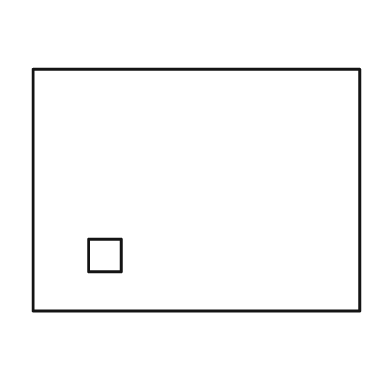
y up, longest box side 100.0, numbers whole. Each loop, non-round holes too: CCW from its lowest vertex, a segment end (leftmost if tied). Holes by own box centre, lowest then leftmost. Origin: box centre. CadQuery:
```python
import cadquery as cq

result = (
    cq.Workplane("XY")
    .moveTo(-50.0, -37.0)
    .lineTo(50.0, -37.0)
    .lineTo(50.0, 37.0)
    .lineTo(-50.0, 37.0)
    .close()
    .moveTo(-33.0, -25.0)
    .lineTo(-23.0, -25.0)
    .lineTo(-23.0, -15.0)
    .lineTo(-33.0, -15.0)
    .close()
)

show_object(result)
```